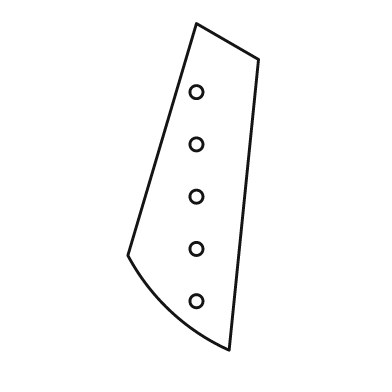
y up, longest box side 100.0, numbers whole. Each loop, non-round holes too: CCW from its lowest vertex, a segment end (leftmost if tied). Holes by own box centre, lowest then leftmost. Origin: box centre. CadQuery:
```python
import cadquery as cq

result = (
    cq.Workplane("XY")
    .moveTo(11.0, -50.0)
    .lineTo(20.0, 39.0)
    .lineTo(1.0, 50.0)
    .lineTo(-20.0, -21.0)
    .threePointArc((-7.0, -38.0), (11.0, -50.0))
    .close()
    .moveTo(1.0, -35.0)
    .circle(2.0)
    .moveTo(1.0, -19.0)
    .circle(2.0)
    .moveTo(1.0, -3.0)
    .circle(2.0)
    .moveTo(1.0, 13.0)
    .circle(2.0)
    .moveTo(1.0, 29.0)
    .circle(2.0)
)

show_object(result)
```